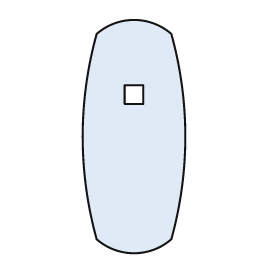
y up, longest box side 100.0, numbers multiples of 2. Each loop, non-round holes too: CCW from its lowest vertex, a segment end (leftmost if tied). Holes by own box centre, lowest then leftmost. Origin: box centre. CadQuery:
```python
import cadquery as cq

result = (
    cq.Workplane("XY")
    .moveTo(-16.0, -44.0)
    .threePointArc((0.0, -50.0), (16.0, -44.0))
    .threePointArc((22.0, 0.0), (16.0, 44.0))
    .threePointArc((0.0, 50.0), (-16.0, 44.0))
    .threePointArc((-22.0, 0.0), (-16.0, -44.0))
    .close()
    .moveTo(-4.0, 14.0)
    .lineTo(4.0, 14.0)
    .lineTo(4.0, 22.0)
    .lineTo(-4.0, 22.0)
    .close()
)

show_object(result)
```